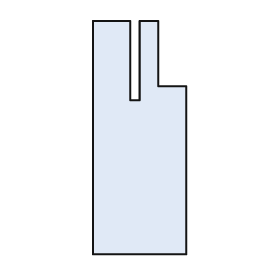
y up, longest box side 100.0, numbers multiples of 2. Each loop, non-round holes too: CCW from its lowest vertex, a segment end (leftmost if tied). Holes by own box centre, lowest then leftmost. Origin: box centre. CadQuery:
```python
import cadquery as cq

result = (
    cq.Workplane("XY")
    .moveTo(-20.0, -50.0)
    .lineTo(20.0, -50.0)
    .lineTo(20.0, 22.0)
    .lineTo(8.0, 22.0)
    .lineTo(8.0, 50.0)
    .lineTo(0.0, 50.0)
    .lineTo(0.0, 16.0)
    .lineTo(-4.0, 16.0)
    .lineTo(-4.0, 50.0)
    .lineTo(-20.0, 50.0)
    .close()
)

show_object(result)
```